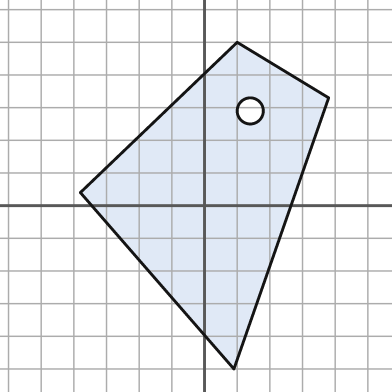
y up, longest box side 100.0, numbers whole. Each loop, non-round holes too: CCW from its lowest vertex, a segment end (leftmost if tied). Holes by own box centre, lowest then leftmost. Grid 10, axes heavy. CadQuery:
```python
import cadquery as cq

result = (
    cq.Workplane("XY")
    .moveTo(9.0, -50.0)
    .lineTo(38.0, 33.0)
    .lineTo(10.0, 50.0)
    .lineTo(-38.0, 4.0)
    .close()
    .moveTo(14.0, 29.0)
    .circle(4.0)
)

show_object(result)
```